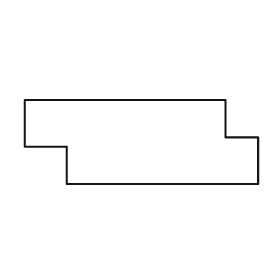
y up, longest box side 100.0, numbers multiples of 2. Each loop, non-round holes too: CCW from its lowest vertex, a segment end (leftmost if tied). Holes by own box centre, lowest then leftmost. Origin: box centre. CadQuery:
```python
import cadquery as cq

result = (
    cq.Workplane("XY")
    .moveTo(-32.0, -18.0)
    .lineTo(50.0, -18.0)
    .lineTo(50.0, 2.0)
    .lineTo(36.0, 2.0)
    .lineTo(36.0, 18.0)
    .lineTo(-50.0, 18.0)
    .lineTo(-50.0, -2.0)
    .lineTo(-32.0, -2.0)
    .close()
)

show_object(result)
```